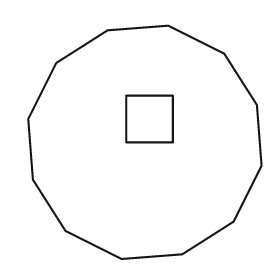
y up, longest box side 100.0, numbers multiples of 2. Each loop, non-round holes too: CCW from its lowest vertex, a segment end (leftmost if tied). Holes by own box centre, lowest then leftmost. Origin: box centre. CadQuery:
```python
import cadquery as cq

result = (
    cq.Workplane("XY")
    .moveTo(-10.0, -50.0)
    .lineTo(16.0, -48.0)
    .lineTo(38.0, -34.0)
    .lineTo(50.0, -10.0)
    .lineTo(48.0, 16.0)
    .lineTo(34.0, 38.0)
    .lineTo(10.0, 50.0)
    .lineTo(-16.0, 48.0)
    .lineTo(-38.0, 34.0)
    .lineTo(-50.0, 10.0)
    .lineTo(-48.0, -16.0)
    .lineTo(-34.0, -38.0)
    .close()
    .moveTo(-8.0, 0.0)
    .lineTo(12.0, 0.0)
    .lineTo(12.0, 20.0)
    .lineTo(-8.0, 20.0)
    .close()
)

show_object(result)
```